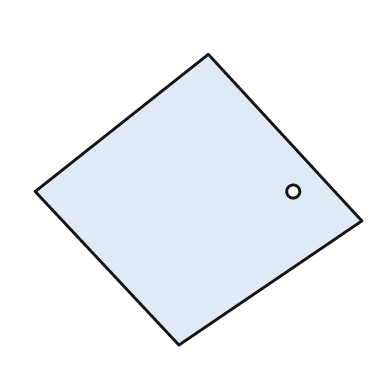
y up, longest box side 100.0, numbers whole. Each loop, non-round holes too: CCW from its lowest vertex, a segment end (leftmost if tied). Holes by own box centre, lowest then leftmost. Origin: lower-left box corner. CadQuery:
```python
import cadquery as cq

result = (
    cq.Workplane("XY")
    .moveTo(44.0, 0.0)
    .lineTo(100.0, 38.0)
    .lineTo(53.0, 89.0)
    .lineTo(0.0, 47.0)
    .close()
    .moveTo(79.0, 47.0)
    .circle(2.0)
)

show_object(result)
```